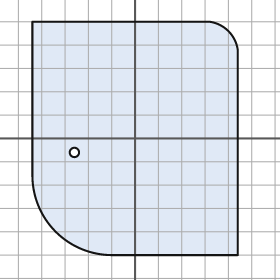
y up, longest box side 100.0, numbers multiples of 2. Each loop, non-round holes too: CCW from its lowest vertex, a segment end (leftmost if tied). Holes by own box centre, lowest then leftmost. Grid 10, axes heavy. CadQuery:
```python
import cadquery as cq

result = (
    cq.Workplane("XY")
    .moveTo(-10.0, -50.0)
    .lineTo(44.0, -50.0)
    .lineTo(44.0, 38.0)
    .threePointArc((40.0, 46.0), (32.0, 50.0))
    .lineTo(-44.0, 50.0)
    .lineTo(-44.0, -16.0)
    .threePointArc((-34.0, -40.0), (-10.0, -50.0))
    .close()
    .moveTo(-26.0, -6.0)
    .circle(2.0)
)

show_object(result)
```